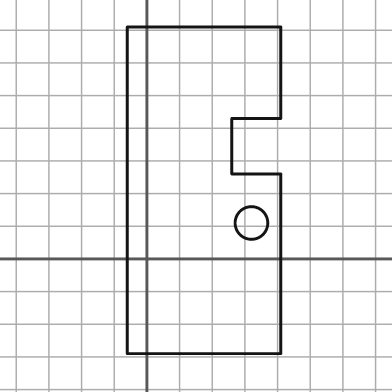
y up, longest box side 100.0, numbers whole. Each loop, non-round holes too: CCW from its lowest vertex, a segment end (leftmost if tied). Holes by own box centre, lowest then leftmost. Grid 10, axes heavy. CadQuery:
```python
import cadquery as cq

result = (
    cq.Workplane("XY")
    .moveTo(-6.0, -29.0)
    .lineTo(41.0, -29.0)
    .lineTo(41.0, 26.0)
    .lineTo(26.0, 26.0)
    .lineTo(26.0, 43.0)
    .lineTo(41.0, 43.0)
    .lineTo(41.0, 71.0)
    .lineTo(-6.0, 71.0)
    .close()
    .moveTo(32.0, 11.0)
    .circle(5.0)
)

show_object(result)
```